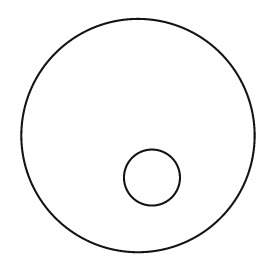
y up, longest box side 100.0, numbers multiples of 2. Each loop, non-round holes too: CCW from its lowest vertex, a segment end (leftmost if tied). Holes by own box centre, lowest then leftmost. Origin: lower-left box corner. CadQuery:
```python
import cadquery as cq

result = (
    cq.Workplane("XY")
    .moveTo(50.0, 50.0)
    .circle(50.0)
    .moveTo(56.0, 32.0)
    .circle(12.0)
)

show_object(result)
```